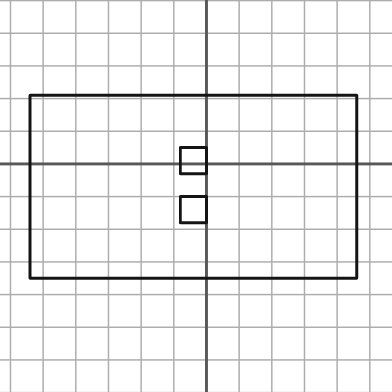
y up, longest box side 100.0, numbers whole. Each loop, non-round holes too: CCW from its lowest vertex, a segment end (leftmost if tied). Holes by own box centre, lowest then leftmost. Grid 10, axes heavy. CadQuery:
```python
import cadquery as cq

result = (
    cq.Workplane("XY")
    .moveTo(-54.0, -35.0)
    .lineTo(46.0, -35.0)
    .lineTo(46.0, 21.0)
    .lineTo(-54.0, 21.0)
    .close()
    .moveTo(-8.0, -18.0)
    .lineTo(0.0, -18.0)
    .lineTo(0.0, -10.0)
    .lineTo(-8.0, -10.0)
    .close()
    .moveTo(-8.0, -3.0)
    .lineTo(0.0, -3.0)
    .lineTo(0.0, 5.0)
    .lineTo(-8.0, 5.0)
    .close()
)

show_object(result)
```